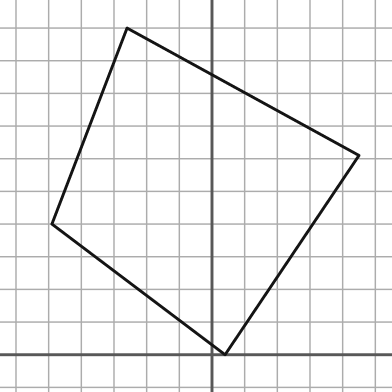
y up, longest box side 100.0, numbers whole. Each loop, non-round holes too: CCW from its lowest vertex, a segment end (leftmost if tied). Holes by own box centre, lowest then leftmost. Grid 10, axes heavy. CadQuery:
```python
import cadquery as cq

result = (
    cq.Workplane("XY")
    .moveTo(4.0, 0.0)
    .lineTo(45.0, 61.0)
    .lineTo(-26.0, 100.0)
    .lineTo(-49.0, 40.0)
    .close()
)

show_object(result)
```